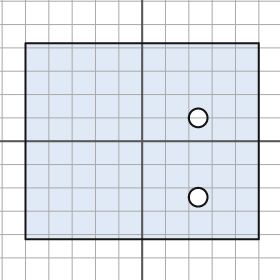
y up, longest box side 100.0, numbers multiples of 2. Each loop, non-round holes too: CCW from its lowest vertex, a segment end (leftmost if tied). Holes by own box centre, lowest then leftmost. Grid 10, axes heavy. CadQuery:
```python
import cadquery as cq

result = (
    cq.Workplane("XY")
    .moveTo(-50.0, -42.0)
    .lineTo(50.0, -42.0)
    .lineTo(50.0, 42.0)
    .lineTo(-50.0, 42.0)
    .close()
    .moveTo(24.0, -24.0)
    .circle(4.0)
    .moveTo(24.0, 10.0)
    .circle(4.0)
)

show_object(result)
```